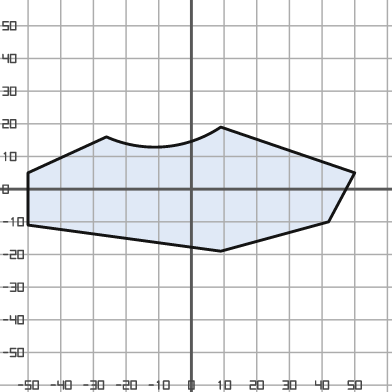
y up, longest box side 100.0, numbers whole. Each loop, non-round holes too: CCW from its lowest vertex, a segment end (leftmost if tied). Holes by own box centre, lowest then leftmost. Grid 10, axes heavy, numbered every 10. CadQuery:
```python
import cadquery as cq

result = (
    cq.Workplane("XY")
    .moveTo(9.0, -19.0)
    .lineTo(42.0, -10.0)
    .lineTo(50.0, 5.0)
    .lineTo(9.0, 19.0)
    .threePointArc((-8.0, 13.0), (-26.0, 16.0))
    .lineTo(-50.0, 5.0)
    .lineTo(-50.0, -11.0)
    .close()
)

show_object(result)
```